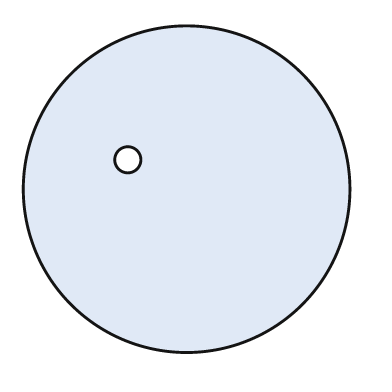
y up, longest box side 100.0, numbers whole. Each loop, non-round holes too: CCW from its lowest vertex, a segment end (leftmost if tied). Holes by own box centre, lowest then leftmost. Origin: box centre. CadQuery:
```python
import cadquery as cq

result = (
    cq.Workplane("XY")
    .moveTo(0.0, 0.0)
    .circle(50.0)
    .moveTo(-18.0, 9.0)
    .circle(4.0)
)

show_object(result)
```